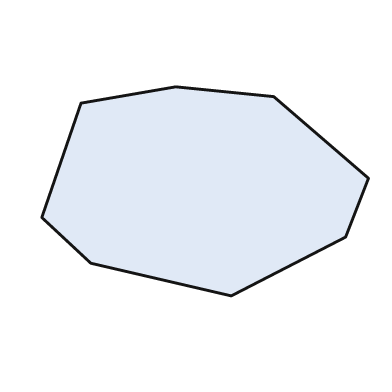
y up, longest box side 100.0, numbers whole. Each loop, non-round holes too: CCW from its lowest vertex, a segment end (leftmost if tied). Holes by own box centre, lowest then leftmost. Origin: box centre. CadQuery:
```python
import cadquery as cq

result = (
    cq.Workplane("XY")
    .moveTo(8.0, -32.0)
    .lineTo(43.0, -14.0)
    .lineTo(50.0, 4.0)
    .lineTo(21.0, 29.0)
    .lineTo(-9.0, 32.0)
    .lineTo(-38.0, 27.0)
    .lineTo(-50.0, -8.0)
    .lineTo(-35.0, -22.0)
    .close()
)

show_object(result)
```